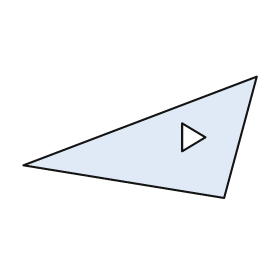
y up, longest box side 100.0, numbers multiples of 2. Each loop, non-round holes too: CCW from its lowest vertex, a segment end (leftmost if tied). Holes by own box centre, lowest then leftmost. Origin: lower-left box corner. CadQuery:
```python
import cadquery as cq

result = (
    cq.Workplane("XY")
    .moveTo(86.0, 0.0)
    .lineTo(100.0, 52.0)
    .lineTo(0.0, 14.0)
    .close()
    .moveTo(68.0, 20.0)
    .lineTo(78.0, 26.0)
    .lineTo(68.0, 32.0)
    .close()
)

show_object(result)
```